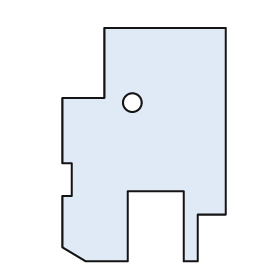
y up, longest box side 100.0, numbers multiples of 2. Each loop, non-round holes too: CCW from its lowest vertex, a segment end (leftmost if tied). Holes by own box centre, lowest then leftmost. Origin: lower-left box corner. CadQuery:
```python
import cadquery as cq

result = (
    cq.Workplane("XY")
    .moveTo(10.0, 0.0)
    .lineTo(28.0, 0.0)
    .lineTo(28.0, 30.0)
    .lineTo(52.0, 30.0)
    .lineTo(52.0, 0.0)
    .lineTo(58.0, 0.0)
    .lineTo(58.0, 20.0)
    .lineTo(70.0, 20.0)
    .lineTo(70.0, 100.0)
    .lineTo(18.0, 100.0)
    .lineTo(18.0, 70.0)
    .lineTo(0.0, 70.0)
    .lineTo(0.0, 42.0)
    .lineTo(4.0, 42.0)
    .lineTo(4.0, 28.0)
    .lineTo(0.0, 28.0)
    .lineTo(0.0, 6.0)
    .close()
    .moveTo(30.0, 68.0)
    .circle(4.0)
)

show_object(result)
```